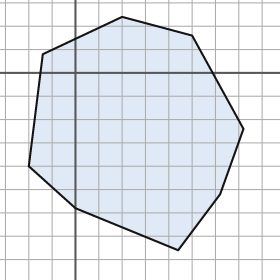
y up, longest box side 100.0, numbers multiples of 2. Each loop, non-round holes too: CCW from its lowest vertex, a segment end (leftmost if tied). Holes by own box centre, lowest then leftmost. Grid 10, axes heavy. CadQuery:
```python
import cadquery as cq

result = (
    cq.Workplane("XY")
    .moveTo(44.0, -76.0)
    .lineTo(62.0, -52.0)
    .lineTo(72.0, -24.0)
    .lineTo(50.0, 16.0)
    .lineTo(20.0, 24.0)
    .lineTo(-14.0, 8.0)
    .lineTo(-20.0, -40.0)
    .lineTo(0.0, -58.0)
    .close()
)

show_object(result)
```